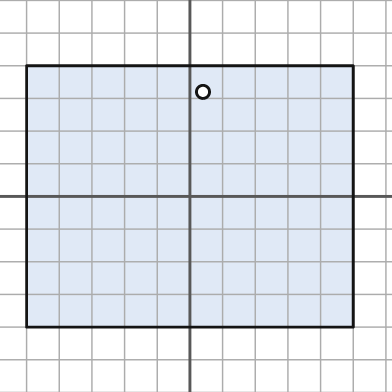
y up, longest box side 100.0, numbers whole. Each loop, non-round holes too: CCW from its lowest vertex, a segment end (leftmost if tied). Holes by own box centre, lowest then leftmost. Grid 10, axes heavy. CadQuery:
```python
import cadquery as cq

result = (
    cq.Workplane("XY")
    .moveTo(-50.0, -40.0)
    .lineTo(50.0, -40.0)
    .lineTo(50.0, 40.0)
    .lineTo(-50.0, 40.0)
    .close()
    .moveTo(4.0, 32.0)
    .circle(2.0)
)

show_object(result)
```